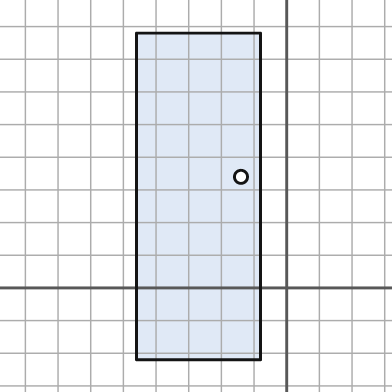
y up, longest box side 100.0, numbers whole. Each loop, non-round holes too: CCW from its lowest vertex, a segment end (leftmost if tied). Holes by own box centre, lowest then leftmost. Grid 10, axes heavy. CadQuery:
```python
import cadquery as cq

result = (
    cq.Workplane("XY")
    .moveTo(-46.0, -22.0)
    .lineTo(-8.0, -22.0)
    .lineTo(-8.0, 78.0)
    .lineTo(-46.0, 78.0)
    .close()
    .moveTo(-14.0, 34.0)
    .circle(2.0)
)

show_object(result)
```